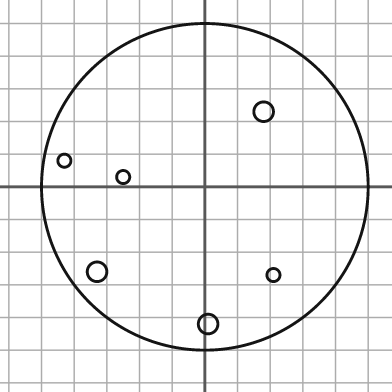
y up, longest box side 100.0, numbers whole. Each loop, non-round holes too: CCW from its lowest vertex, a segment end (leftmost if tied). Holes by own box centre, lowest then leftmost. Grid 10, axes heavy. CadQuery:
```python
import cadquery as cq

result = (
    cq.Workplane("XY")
    .moveTo(0.0, 0.0)
    .circle(50.0)
    .moveTo(1.0, -42.0)
    .circle(3.0)
    .moveTo(21.0, -27.0)
    .circle(2.0)
    .moveTo(-33.0, -26.0)
    .circle(3.0)
    .moveTo(-25.0, 3.0)
    .circle(2.0)
    .moveTo(-43.0, 8.0)
    .circle(2.0)
    .moveTo(18.0, 23.0)
    .circle(3.0)
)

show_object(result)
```